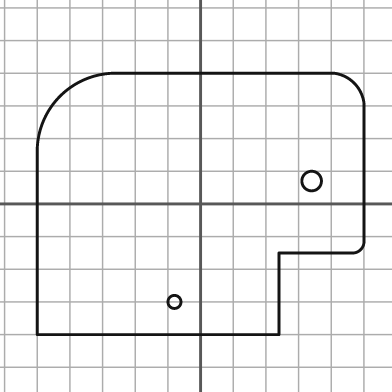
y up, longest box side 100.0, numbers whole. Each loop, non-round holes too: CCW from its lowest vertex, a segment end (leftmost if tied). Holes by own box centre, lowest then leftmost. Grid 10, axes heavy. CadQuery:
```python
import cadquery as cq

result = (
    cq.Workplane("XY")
    .moveTo(-50.0, -40.0)
    .lineTo(24.0, -40.0)
    .lineTo(24.0, -15.0)
    .lineTo(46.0, -15.0)
    .threePointArc((49.0, -14.0), (50.0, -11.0))
    .lineTo(50.0, 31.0)
    .threePointArc((47.0, 37.0), (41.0, 40.0))
    .lineTo(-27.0, 40.0)
    .threePointArc((-43.0, 33.0), (-50.0, 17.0))
    .close()
    .moveTo(-8.0, -30.0)
    .circle(2.0)
    .moveTo(34.0, 7.0)
    .circle(3.0)
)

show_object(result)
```